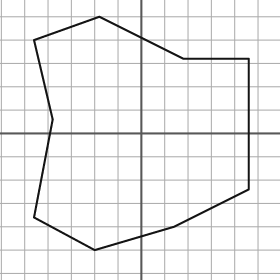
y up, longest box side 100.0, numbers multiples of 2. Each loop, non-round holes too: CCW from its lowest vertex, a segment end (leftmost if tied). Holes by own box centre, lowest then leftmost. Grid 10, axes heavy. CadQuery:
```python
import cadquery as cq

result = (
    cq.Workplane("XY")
    .moveTo(-20.0, -50.0)
    .lineTo(14.0, -40.0)
    .lineTo(46.0, -24.0)
    .lineTo(46.0, 32.0)
    .lineTo(18.0, 32.0)
    .lineTo(-18.0, 50.0)
    .lineTo(-46.0, 40.0)
    .lineTo(-38.0, 6.0)
    .lineTo(-46.0, -36.0)
    .close()
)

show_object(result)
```